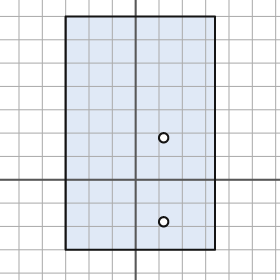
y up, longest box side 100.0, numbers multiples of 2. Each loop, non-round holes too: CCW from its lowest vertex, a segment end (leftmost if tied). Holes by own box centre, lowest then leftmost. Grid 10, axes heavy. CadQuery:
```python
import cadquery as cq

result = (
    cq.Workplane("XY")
    .moveTo(-30.0, -30.0)
    .lineTo(34.0, -30.0)
    .lineTo(34.0, 70.0)
    .lineTo(-30.0, 70.0)
    .close()
    .moveTo(12.0, -18.0)
    .circle(2.0)
    .moveTo(12.0, 18.0)
    .circle(2.0)
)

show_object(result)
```